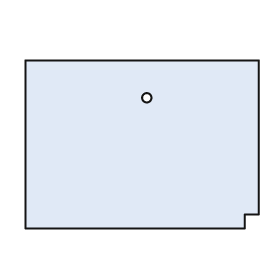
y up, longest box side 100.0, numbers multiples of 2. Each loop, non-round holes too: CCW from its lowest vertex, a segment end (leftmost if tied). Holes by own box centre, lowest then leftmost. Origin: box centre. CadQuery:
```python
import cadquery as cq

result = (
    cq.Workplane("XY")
    .moveTo(-50.0, -36.0)
    .lineTo(44.0, -36.0)
    .lineTo(44.0, -30.0)
    .lineTo(50.0, -30.0)
    .lineTo(50.0, 36.0)
    .lineTo(-50.0, 36.0)
    .close()
    .moveTo(2.0, 20.0)
    .circle(2.0)
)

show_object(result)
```